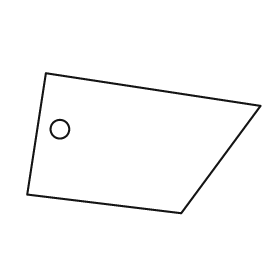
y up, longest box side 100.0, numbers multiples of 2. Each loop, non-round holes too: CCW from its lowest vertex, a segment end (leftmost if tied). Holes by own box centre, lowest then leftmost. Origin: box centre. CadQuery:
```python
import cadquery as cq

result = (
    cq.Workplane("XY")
    .moveTo(16.0, -30.0)
    .lineTo(50.0, 16.0)
    .lineTo(-42.0, 30.0)
    .lineTo(-50.0, -22.0)
    .close()
    .moveTo(-36.0, 6.0)
    .circle(4.0)
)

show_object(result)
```